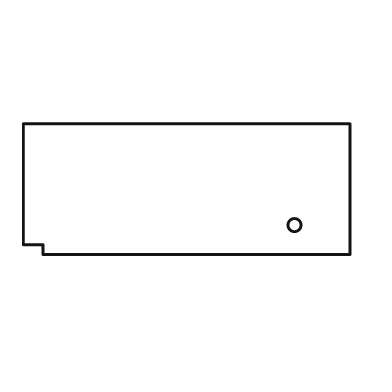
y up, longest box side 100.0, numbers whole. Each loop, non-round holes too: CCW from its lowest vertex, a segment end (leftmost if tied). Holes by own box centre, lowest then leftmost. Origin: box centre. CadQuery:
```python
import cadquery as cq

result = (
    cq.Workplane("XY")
    .moveTo(-44.0, -20.0)
    .lineTo(50.0, -20.0)
    .lineTo(50.0, 20.0)
    .lineTo(-50.0, 20.0)
    .lineTo(-50.0, -17.0)
    .lineTo(-44.0, -17.0)
    .close()
    .moveTo(33.0, -11.0)
    .circle(2.0)
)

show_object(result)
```